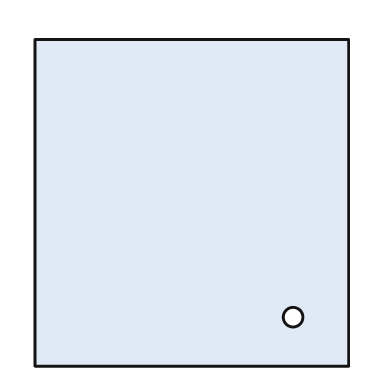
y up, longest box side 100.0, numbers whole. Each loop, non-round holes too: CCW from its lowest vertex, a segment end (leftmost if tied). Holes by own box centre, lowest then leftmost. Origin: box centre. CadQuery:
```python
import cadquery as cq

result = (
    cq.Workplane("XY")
    .moveTo(-48.0, -50.0)
    .lineTo(48.0, -50.0)
    .lineTo(48.0, 50.0)
    .lineTo(-48.0, 50.0)
    .close()
    .moveTo(31.0, -35.0)
    .circle(3.0)
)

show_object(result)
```